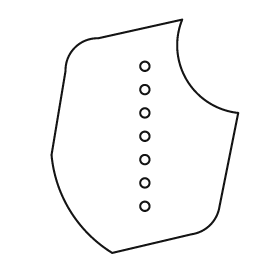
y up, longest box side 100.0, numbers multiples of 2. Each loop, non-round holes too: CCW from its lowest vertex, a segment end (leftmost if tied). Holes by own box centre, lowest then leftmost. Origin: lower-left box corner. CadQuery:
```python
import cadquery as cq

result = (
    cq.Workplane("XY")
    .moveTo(26.0, 0.0)
    .lineTo(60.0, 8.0)
    .threePointArc((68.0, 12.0), (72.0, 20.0))
    .lineTo(80.0, 60.0)
    .threePointArc((58.0, 74.0), (56.0, 100.0))
    .lineTo(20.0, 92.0)
    .threePointArc((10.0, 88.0), (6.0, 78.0))
    .lineTo(0.0, 42.0)
    .threePointArc((8.0, 18.0), (26.0, 0.0))
    .close()
    .moveTo(40.0, 20.0)
    .circle(2.0)
    .moveTo(40.0, 30.0)
    .circle(2.0)
    .moveTo(40.0, 40.0)
    .circle(2.0)
    .moveTo(40.0, 50.0)
    .circle(2.0)
    .moveTo(40.0, 60.0)
    .circle(2.0)
    .moveTo(40.0, 70.0)
    .circle(2.0)
    .moveTo(40.0, 80.0)
    .circle(2.0)
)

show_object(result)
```